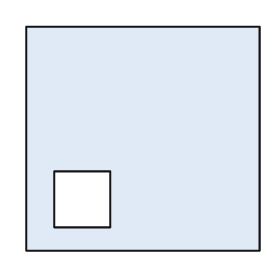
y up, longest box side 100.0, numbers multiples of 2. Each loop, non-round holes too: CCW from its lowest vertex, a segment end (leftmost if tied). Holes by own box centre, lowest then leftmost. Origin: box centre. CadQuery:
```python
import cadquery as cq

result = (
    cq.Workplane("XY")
    .moveTo(-50.0, -48.0)
    .lineTo(50.0, -48.0)
    .lineTo(50.0, 48.0)
    .lineTo(-50.0, 48.0)
    .close()
    .moveTo(-38.0, -38.0)
    .lineTo(-14.0, -38.0)
    .lineTo(-14.0, -14.0)
    .lineTo(-38.0, -14.0)
    .close()
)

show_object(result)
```